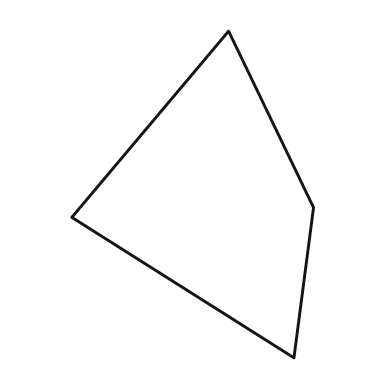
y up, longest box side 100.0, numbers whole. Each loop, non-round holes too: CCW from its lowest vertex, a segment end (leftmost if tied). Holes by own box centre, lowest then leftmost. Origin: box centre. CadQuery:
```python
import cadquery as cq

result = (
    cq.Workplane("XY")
    .moveTo(31.0, -50.0)
    .lineTo(37.0, -4.0)
    .lineTo(11.0, 50.0)
    .lineTo(-37.0, -7.0)
    .close()
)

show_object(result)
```